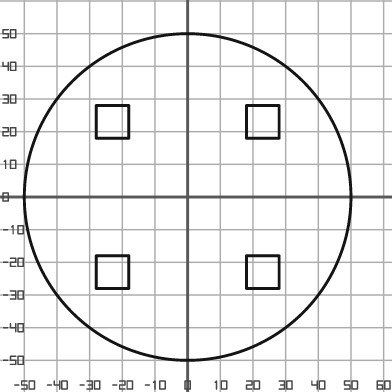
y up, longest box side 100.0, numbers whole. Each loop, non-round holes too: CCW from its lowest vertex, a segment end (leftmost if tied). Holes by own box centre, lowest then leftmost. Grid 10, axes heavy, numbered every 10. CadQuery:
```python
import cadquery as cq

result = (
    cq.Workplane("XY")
    .moveTo(0.0, 0.0)
    .circle(50.0)
    .moveTo(-28.0, -28.0)
    .lineTo(-18.0, -28.0)
    .lineTo(-18.0, -18.0)
    .lineTo(-28.0, -18.0)
    .close()
    .moveTo(18.0, -28.0)
    .lineTo(28.0, -28.0)
    .lineTo(28.0, -18.0)
    .lineTo(18.0, -18.0)
    .close()
    .moveTo(-28.0, 18.0)
    .lineTo(-18.0, 18.0)
    .lineTo(-18.0, 28.0)
    .lineTo(-28.0, 28.0)
    .close()
    .moveTo(18.0, 18.0)
    .lineTo(28.0, 18.0)
    .lineTo(28.0, 28.0)
    .lineTo(18.0, 28.0)
    .close()
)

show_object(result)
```